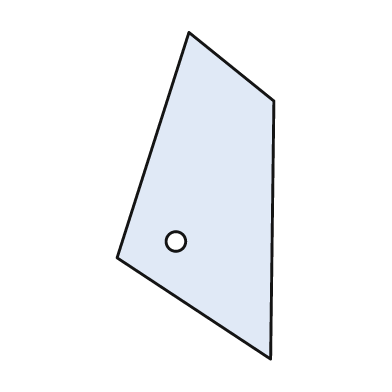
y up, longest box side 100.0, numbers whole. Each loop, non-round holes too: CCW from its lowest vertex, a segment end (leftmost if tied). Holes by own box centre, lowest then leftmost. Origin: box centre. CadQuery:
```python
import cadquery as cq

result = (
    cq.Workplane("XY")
    .moveTo(23.0, -50.0)
    .lineTo(24.0, 29.0)
    .lineTo(-2.0, 50.0)
    .lineTo(-24.0, -19.0)
    .close()
    .moveTo(-6.0, -14.0)
    .circle(3.0)
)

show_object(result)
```